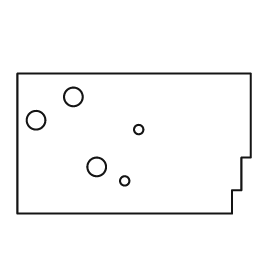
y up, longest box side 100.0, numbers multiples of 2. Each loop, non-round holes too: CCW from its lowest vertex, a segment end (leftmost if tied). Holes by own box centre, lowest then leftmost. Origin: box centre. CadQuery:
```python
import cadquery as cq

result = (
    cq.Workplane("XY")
    .moveTo(-50.0, -30.0)
    .lineTo(42.0, -30.0)
    .lineTo(42.0, -20.0)
    .lineTo(46.0, -20.0)
    .lineTo(46.0, -6.0)
    .lineTo(50.0, -6.0)
    .lineTo(50.0, 30.0)
    .lineTo(-50.0, 30.0)
    .close()
    .moveTo(-4.0, -16.0)
    .circle(2.0)
    .moveTo(-16.0, -10.0)
    .circle(4.0)
    .moveTo(2.0, 6.0)
    .circle(2.0)
    .moveTo(-42.0, 10.0)
    .circle(4.0)
    .moveTo(-26.0, 20.0)
    .circle(4.0)
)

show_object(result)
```